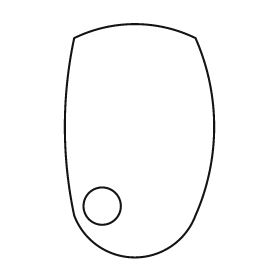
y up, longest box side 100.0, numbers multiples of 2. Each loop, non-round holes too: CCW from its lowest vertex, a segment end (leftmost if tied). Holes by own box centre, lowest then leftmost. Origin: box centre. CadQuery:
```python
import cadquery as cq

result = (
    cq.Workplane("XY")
    .moveTo(-28.0, -32.0)
    .threePointArc((-2.0, -50.0), (24.0, -32.0))
    .threePointArc((32.0, 6.0), (24.0, 44.0))
    .threePointArc((-2.0, 50.0), (-28.0, 44.0))
    .threePointArc((-32.0, 6.0), (-28.0, -32.0))
    .close()
    .moveTo(-16.0, -28.0)
    .circle(8.0)
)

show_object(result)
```